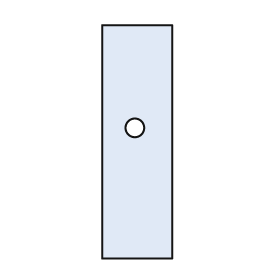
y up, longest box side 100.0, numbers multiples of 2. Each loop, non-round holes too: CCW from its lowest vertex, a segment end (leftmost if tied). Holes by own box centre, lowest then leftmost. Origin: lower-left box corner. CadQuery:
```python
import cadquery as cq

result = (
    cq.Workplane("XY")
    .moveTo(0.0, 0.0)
    .lineTo(30.0, 0.0)
    .lineTo(30.0, 100.0)
    .lineTo(0.0, 100.0)
    .close()
    .moveTo(14.0, 56.0)
    .circle(4.0)
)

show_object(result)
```